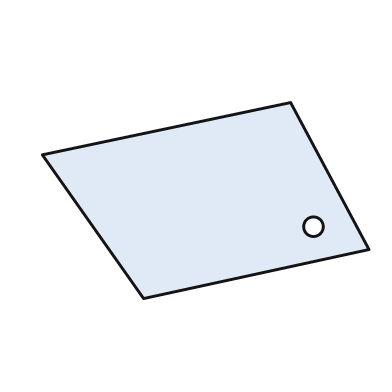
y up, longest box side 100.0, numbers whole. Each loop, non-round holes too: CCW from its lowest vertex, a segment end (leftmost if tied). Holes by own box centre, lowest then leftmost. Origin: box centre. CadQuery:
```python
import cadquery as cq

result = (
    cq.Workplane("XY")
    .moveTo(-19.0, -30.0)
    .lineTo(50.0, -15.0)
    .lineTo(26.0, 30.0)
    .lineTo(-50.0, 14.0)
    .close()
    .moveTo(33.0, -8.0)
    .circle(3.0)
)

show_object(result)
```